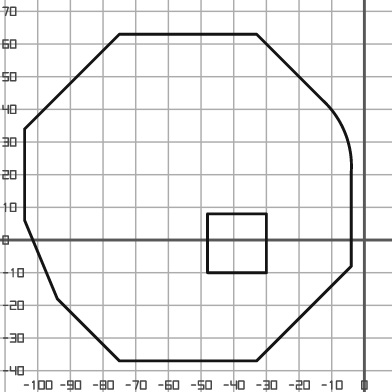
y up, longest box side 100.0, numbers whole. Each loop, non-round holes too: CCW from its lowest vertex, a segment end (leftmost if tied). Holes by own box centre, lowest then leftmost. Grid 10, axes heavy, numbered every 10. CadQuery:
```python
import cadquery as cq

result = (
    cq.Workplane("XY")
    .moveTo(-75.0, -37.0)
    .lineTo(-33.0, -37.0)
    .lineTo(-4.0, -8.0)
    .lineTo(-4.0, 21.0)
    .threePointArc((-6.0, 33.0), (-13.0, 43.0))
    .lineTo(-33.0, 63.0)
    .lineTo(-75.0, 63.0)
    .lineTo(-104.0, 34.0)
    .lineTo(-104.0, 6.0)
    .lineTo(-94.0, -18.0)
    .close()
    .moveTo(-48.0, -10.0)
    .lineTo(-30.0, -10.0)
    .lineTo(-30.0, 8.0)
    .lineTo(-48.0, 8.0)
    .close()
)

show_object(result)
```